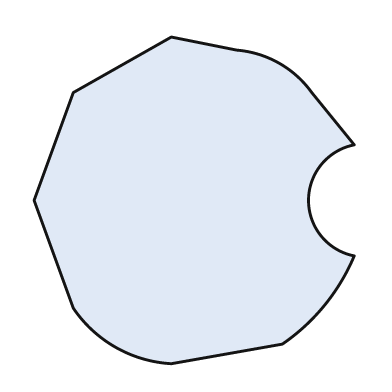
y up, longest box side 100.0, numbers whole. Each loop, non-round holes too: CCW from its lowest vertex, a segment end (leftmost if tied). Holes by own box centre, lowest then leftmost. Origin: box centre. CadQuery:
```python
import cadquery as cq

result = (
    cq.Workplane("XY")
    .moveTo(-7.0, -50.0)
    .lineTo(27.0, -44.0)
    .threePointArc((40.0, -32.0), (49.0, -17.0))
    .threePointArc((35.0, 0.0), (49.0, 17.0))
    .lineTo(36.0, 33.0)
    .threePointArc((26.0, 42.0), (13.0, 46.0))
    .lineTo(-7.0, 50.0)
    .lineTo(-37.0, 33.0)
    .lineTo(-49.0, 0.0)
    .lineTo(-37.0, -33.0)
    .threePointArc((-24.0, -45.0), (-7.0, -50.0))
    .close()
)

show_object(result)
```